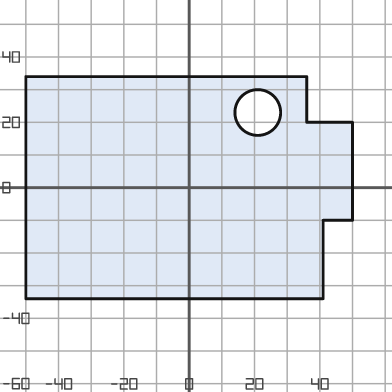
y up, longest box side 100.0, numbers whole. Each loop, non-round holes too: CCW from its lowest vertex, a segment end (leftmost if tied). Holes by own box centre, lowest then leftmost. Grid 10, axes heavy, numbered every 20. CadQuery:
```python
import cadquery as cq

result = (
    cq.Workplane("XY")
    .moveTo(-50.0, -34.0)
    .lineTo(41.0, -34.0)
    .lineTo(41.0, -10.0)
    .lineTo(50.0, -10.0)
    .lineTo(50.0, 20.0)
    .lineTo(36.0, 20.0)
    .lineTo(36.0, 34.0)
    .lineTo(-50.0, 34.0)
    .close()
    .moveTo(21.0, 23.0)
    .circle(7.0)
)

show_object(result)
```